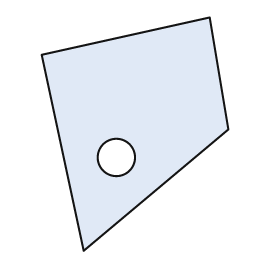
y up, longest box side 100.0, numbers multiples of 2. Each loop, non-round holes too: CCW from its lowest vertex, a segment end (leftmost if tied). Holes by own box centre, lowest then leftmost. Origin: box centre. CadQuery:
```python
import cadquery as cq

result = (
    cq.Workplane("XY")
    .moveTo(-22.0, -50.0)
    .lineTo(40.0, 2.0)
    .lineTo(32.0, 50.0)
    .lineTo(-40.0, 34.0)
    .close()
    .moveTo(-8.0, -10.0)
    .circle(8.0)
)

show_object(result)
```